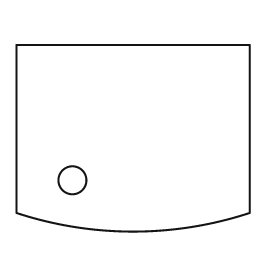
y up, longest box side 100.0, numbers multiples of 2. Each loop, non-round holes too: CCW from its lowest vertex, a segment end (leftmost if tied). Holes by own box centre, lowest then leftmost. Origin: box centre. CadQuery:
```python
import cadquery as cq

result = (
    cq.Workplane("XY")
    .moveTo(-50.0, -32.0)
    .threePointArc((0.0, -40.0), (50.0, -32.0))
    .lineTo(50.0, 40.0)
    .lineTo(-50.0, 40.0)
    .close()
    .moveTo(-26.0, -18.0)
    .circle(6.0)
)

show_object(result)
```